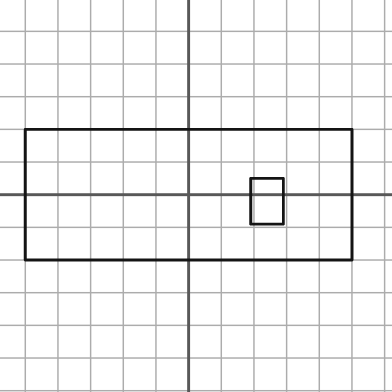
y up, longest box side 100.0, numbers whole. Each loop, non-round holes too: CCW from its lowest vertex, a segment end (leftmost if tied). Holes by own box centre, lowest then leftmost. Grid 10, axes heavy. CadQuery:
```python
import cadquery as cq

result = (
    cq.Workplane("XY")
    .moveTo(-50.0, -20.0)
    .lineTo(50.0, -20.0)
    .lineTo(50.0, 20.0)
    .lineTo(-50.0, 20.0)
    .close()
    .moveTo(19.0, -9.0)
    .lineTo(29.0, -9.0)
    .lineTo(29.0, 5.0)
    .lineTo(19.0, 5.0)
    .close()
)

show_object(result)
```